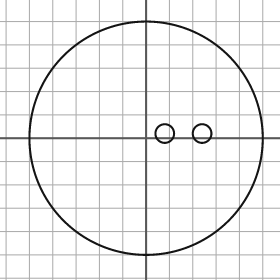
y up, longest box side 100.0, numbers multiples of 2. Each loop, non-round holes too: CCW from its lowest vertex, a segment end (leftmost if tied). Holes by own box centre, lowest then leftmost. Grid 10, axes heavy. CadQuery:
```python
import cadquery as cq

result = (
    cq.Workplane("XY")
    .moveTo(0.0, 0.0)
    .circle(50.0)
    .moveTo(8.0, 2.0)
    .circle(4.0)
    .moveTo(24.0, 2.0)
    .circle(4.0)
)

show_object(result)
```